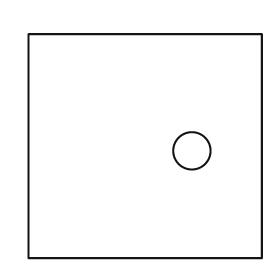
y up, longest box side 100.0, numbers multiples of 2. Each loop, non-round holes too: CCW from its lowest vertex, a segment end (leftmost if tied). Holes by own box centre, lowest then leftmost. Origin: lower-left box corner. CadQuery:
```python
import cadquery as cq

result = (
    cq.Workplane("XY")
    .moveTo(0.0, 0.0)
    .lineTo(100.0, 0.0)
    .lineTo(100.0, 96.0)
    .lineTo(0.0, 96.0)
    .close()
    .moveTo(70.0, 46.0)
    .circle(8.0)
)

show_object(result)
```